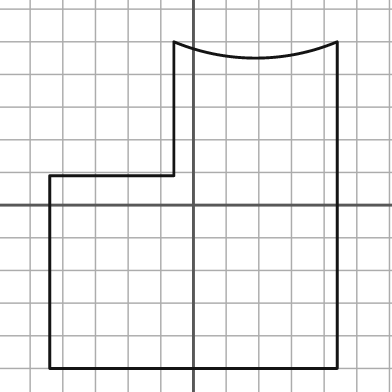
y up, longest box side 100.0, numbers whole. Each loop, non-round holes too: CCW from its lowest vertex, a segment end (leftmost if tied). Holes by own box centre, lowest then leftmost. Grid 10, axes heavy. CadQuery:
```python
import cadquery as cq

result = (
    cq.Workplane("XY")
    .moveTo(-44.0, -50.0)
    .lineTo(44.0, -50.0)
    .lineTo(44.0, 50.0)
    .threePointArc((19.0, 45.0), (-6.0, 50.0))
    .lineTo(-6.0, 9.0)
    .lineTo(-44.0, 9.0)
    .close()
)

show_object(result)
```